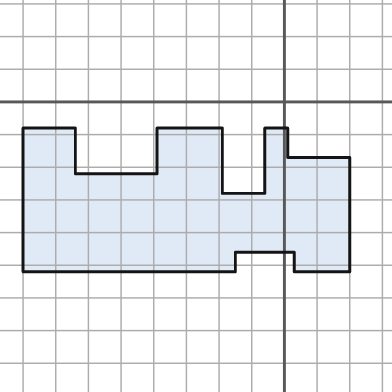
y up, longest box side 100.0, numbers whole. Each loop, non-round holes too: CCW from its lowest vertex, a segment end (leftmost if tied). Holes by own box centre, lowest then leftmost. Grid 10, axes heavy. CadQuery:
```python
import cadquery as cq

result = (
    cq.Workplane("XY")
    .moveTo(-80.0, -52.0)
    .lineTo(-15.0, -52.0)
    .lineTo(-15.0, -46.0)
    .lineTo(3.0, -46.0)
    .lineTo(3.0, -52.0)
    .lineTo(20.0, -52.0)
    .lineTo(20.0, -17.0)
    .lineTo(1.0, -17.0)
    .lineTo(1.0, -8.0)
    .lineTo(-6.0, -8.0)
    .lineTo(-6.0, -28.0)
    .lineTo(-19.0, -28.0)
    .lineTo(-19.0, -8.0)
    .lineTo(-39.0, -8.0)
    .lineTo(-39.0, -22.0)
    .lineTo(-64.0, -22.0)
    .lineTo(-64.0, -8.0)
    .lineTo(-80.0, -8.0)
    .close()
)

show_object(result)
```